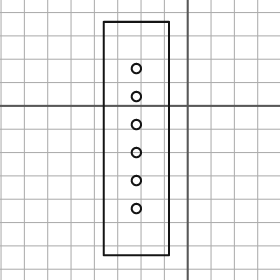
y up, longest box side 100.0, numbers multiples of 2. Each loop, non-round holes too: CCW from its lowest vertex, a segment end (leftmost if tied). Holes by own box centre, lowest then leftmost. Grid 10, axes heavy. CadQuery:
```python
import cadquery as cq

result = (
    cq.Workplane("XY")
    .moveTo(-36.0, -64.0)
    .lineTo(-8.0, -64.0)
    .lineTo(-8.0, 36.0)
    .lineTo(-36.0, 36.0)
    .close()
    .moveTo(-22.0, -44.0)
    .circle(2.0)
    .moveTo(-22.0, -32.0)
    .circle(2.0)
    .moveTo(-22.0, -20.0)
    .circle(2.0)
    .moveTo(-22.0, -8.0)
    .circle(2.0)
    .moveTo(-22.0, 4.0)
    .circle(2.0)
    .moveTo(-22.0, 16.0)
    .circle(2.0)
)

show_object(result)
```